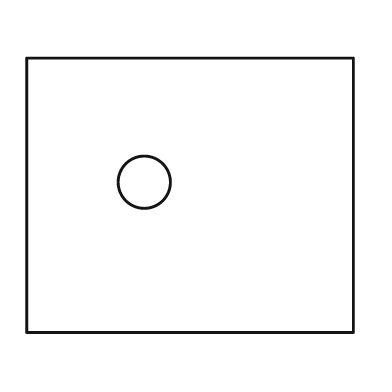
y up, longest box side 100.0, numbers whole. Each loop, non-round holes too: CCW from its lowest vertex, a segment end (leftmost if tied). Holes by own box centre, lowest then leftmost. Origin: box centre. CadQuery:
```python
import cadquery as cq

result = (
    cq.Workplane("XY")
    .moveTo(-50.0, -42.0)
    .lineTo(50.0, -42.0)
    .lineTo(50.0, 42.0)
    .lineTo(-50.0, 42.0)
    .close()
    .moveTo(-14.0, 4.0)
    .circle(8.0)
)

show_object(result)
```